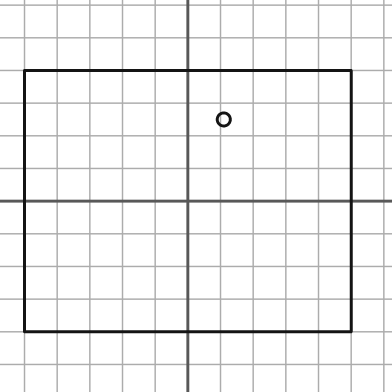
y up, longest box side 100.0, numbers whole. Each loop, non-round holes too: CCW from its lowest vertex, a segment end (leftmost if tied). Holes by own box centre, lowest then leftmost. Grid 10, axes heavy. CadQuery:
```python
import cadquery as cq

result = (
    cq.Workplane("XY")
    .moveTo(-50.0, -40.0)
    .lineTo(50.0, -40.0)
    .lineTo(50.0, 40.0)
    .lineTo(-50.0, 40.0)
    .close()
    .moveTo(11.0, 25.0)
    .circle(2.0)
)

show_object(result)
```